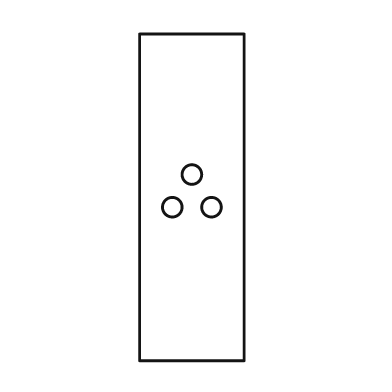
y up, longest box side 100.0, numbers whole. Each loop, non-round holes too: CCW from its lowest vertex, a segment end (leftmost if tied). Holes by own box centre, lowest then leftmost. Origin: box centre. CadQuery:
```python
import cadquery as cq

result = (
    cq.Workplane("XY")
    .moveTo(-16.0, -50.0)
    .lineTo(16.0, -50.0)
    .lineTo(16.0, 50.0)
    .lineTo(-16.0, 50.0)
    .close()
    .moveTo(-6.0, -3.0)
    .circle(3.0)
    .moveTo(6.0, -3.0)
    .circle(3.0)
    .moveTo(0.0, 7.0)
    .circle(3.0)
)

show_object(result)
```